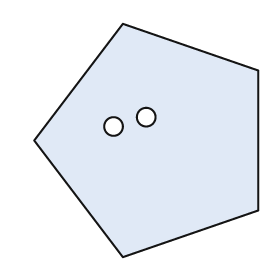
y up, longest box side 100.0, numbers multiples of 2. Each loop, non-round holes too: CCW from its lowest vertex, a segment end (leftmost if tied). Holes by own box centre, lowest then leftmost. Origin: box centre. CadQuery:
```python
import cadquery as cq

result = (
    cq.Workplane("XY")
    .moveTo(-10.0, -50.0)
    .lineTo(48.0, -30.0)
    .lineTo(48.0, 30.0)
    .lineTo(-10.0, 50.0)
    .lineTo(-48.0, 0.0)
    .close()
    .moveTo(-14.0, 6.0)
    .circle(4.0)
    .moveTo(0.0, 10.0)
    .circle(4.0)
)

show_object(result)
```